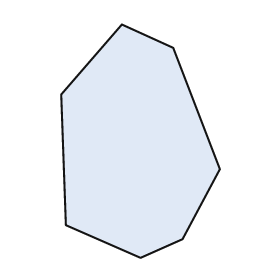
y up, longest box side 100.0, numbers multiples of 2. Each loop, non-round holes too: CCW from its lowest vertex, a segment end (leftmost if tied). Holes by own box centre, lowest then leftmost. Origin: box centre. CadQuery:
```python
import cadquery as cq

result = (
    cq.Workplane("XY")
    .moveTo(0.0, -50.0)
    .lineTo(18.0, -42.0)
    .lineTo(34.0, -12.0)
    .lineTo(14.0, 40.0)
    .lineTo(-8.0, 50.0)
    .lineTo(-34.0, 20.0)
    .lineTo(-32.0, -36.0)
    .close()
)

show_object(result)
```